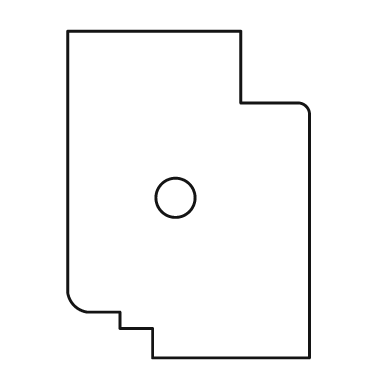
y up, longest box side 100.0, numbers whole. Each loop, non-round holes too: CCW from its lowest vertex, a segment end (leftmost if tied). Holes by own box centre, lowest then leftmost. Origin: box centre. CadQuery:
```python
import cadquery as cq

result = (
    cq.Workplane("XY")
    .moveTo(-11.0, -50.0)
    .lineTo(37.0, -50.0)
    .lineTo(37.0, 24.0)
    .threePointArc((36.0, 27.0), (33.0, 28.0))
    .lineTo(16.0, 28.0)
    .lineTo(16.0, 50.0)
    .lineTo(-37.0, 50.0)
    .lineTo(-37.0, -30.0)
    .threePointArc((-35.0, -34.0), (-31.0, -36.0))
    .lineTo(-21.0, -36.0)
    .lineTo(-21.0, -41.0)
    .lineTo(-11.0, -41.0)
    .close()
    .moveTo(-4.0, -1.0)
    .circle(6.0)
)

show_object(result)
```